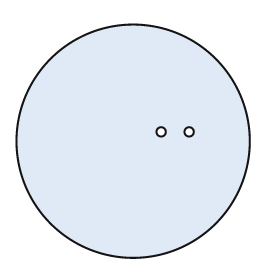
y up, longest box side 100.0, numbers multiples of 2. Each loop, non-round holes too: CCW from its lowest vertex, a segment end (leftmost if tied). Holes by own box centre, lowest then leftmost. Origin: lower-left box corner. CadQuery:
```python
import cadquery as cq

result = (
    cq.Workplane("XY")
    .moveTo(50.0, 50.0)
    .circle(50.0)
    .moveTo(62.0, 54.0)
    .circle(2.0)
    .moveTo(74.0, 54.0)
    .circle(2.0)
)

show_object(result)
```